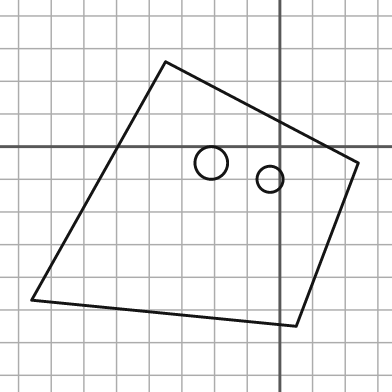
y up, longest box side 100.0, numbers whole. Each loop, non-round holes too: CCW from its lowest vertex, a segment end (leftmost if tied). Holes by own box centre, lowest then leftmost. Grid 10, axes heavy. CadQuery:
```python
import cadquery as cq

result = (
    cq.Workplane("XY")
    .moveTo(5.0, -55.0)
    .lineTo(24.0, -5.0)
    .lineTo(-35.0, 26.0)
    .lineTo(-76.0, -47.0)
    .close()
    .moveTo(-3.0, -10.0)
    .circle(4.0)
    .moveTo(-21.0, -5.0)
    .circle(5.0)
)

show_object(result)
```